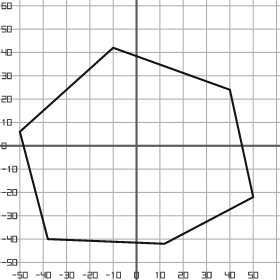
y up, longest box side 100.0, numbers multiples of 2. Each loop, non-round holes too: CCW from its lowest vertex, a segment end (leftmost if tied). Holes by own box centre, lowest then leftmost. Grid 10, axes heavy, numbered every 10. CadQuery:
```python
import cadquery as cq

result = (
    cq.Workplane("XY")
    .moveTo(12.0, -42.0)
    .lineTo(50.0, -22.0)
    .lineTo(40.0, 24.0)
    .lineTo(-10.0, 42.0)
    .lineTo(-50.0, 6.0)
    .lineTo(-38.0, -40.0)
    .close()
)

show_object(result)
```